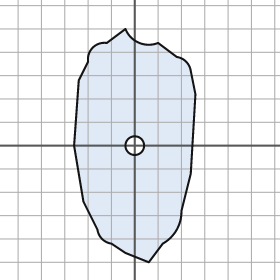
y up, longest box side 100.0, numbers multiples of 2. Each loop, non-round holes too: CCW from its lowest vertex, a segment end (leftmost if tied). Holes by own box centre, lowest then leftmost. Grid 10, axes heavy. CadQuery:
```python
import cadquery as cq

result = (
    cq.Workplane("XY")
    .moveTo(6.0, -50.0)
    .lineTo(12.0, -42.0)
    .threePointArc((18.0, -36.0), (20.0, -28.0))
    .lineTo(24.0, -12.0)
    .lineTo(26.0, 22.0)
    .lineTo(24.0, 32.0)
    .threePointArc((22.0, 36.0), (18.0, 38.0))
    .lineTo(10.0, 44.0)
    .threePointArc((2.0, 44.0), (-4.0, 50.0))
    .lineTo(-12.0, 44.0)
    .threePointArc((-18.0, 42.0), (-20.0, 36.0))
    .lineTo(-24.0, 28.0)
    .lineTo(-26.0, 0.0)
    .lineTo(-22.0, -24.0)
    .lineTo(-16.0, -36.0)
    .threePointArc((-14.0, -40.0), (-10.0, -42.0))
    .lineTo(-4.0, -46.0)
    .close()
    .moveTo(0.0, 0.0)
    .circle(4.0)
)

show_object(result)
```